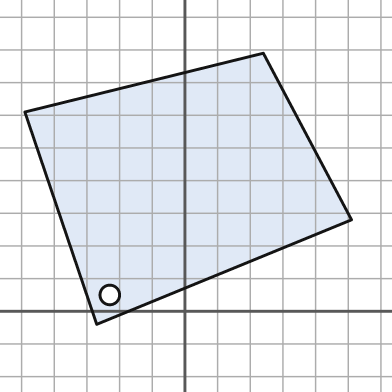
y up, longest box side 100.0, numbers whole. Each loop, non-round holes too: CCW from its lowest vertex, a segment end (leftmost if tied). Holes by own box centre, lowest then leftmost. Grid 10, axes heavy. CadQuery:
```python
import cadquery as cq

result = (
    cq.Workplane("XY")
    .moveTo(-27.0, -4.0)
    .lineTo(51.0, 28.0)
    .lineTo(24.0, 79.0)
    .lineTo(-49.0, 61.0)
    .close()
    .moveTo(-23.0, 5.0)
    .circle(3.0)
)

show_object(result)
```